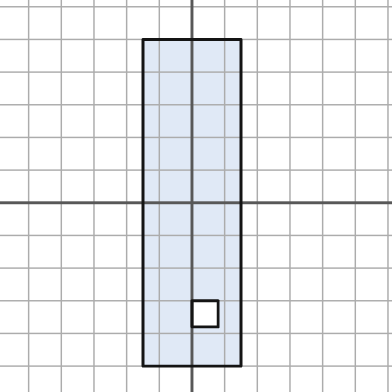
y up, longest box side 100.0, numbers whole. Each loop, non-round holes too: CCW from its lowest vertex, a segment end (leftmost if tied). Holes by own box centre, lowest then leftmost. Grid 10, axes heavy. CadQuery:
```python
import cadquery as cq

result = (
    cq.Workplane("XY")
    .moveTo(-15.0, -50.0)
    .lineTo(15.0, -50.0)
    .lineTo(15.0, 50.0)
    .lineTo(-15.0, 50.0)
    .close()
    .moveTo(0.0, -38.0)
    .lineTo(8.0, -38.0)
    .lineTo(8.0, -30.0)
    .lineTo(0.0, -30.0)
    .close()
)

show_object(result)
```